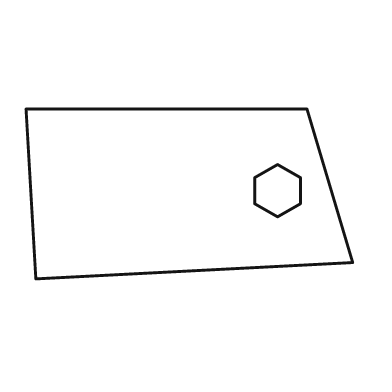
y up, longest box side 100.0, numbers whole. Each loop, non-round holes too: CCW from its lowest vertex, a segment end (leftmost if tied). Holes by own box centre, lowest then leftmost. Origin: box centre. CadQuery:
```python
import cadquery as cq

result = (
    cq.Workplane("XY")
    .moveTo(-47.0, -26.0)
    .lineTo(50.0, -21.0)
    .lineTo(36.0, 26.0)
    .lineTo(-50.0, 26.0)
    .close()
    .moveTo(27.0, -7.0)
    .lineTo(34.0, -3.0)
    .lineTo(34.0, 5.0)
    .lineTo(27.0, 9.0)
    .lineTo(20.0, 5.0)
    .lineTo(20.0, -3.0)
    .close()
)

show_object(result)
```